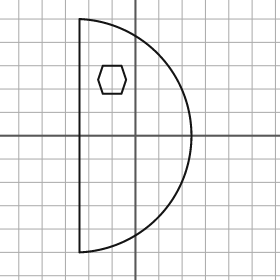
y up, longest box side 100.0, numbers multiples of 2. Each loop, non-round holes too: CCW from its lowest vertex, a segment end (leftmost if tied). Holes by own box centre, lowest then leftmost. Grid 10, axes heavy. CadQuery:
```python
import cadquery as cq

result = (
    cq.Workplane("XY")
    .moveTo(-24.0, -50.0)
    .threePointArc((24.0, 0.0), (-24.0, 50.0))
    .close()
    .moveTo(-14.0, 18.0)
    .lineTo(-6.0, 18.0)
    .lineTo(-4.0, 24.0)
    .lineTo(-6.0, 30.0)
    .lineTo(-14.0, 30.0)
    .lineTo(-16.0, 24.0)
    .close()
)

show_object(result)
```